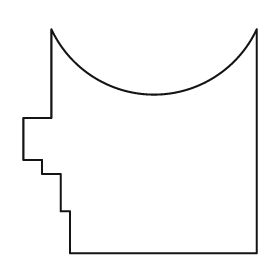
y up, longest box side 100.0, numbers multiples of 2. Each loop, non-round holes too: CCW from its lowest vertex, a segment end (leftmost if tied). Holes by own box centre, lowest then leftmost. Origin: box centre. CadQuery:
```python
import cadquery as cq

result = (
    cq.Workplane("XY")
    .moveTo(-30.0, -48.0)
    .lineTo(50.0, -48.0)
    .lineTo(50.0, 48.0)
    .threePointArc((6.0, 20.0), (-38.0, 48.0))
    .lineTo(-38.0, 10.0)
    .lineTo(-50.0, 10.0)
    .lineTo(-50.0, -8.0)
    .lineTo(-42.0, -8.0)
    .lineTo(-42.0, -14.0)
    .lineTo(-34.0, -14.0)
    .lineTo(-34.0, -30.0)
    .lineTo(-30.0, -30.0)
    .close()
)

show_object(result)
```